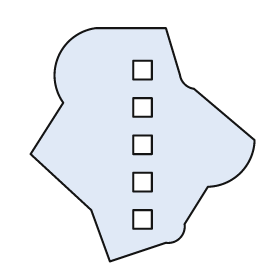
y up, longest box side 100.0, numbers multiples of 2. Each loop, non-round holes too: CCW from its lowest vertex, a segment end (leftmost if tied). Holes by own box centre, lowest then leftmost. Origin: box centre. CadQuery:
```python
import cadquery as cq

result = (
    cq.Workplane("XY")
    .moveTo(-14.0, -50.0)
    .lineTo(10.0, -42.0)
    .threePointArc((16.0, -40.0), (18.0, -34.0))
    .lineTo(28.0, -18.0)
    .threePointArc((42.0, -12.0), (48.0, 2.0))
    .lineTo(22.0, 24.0)
    .threePointArc((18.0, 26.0), (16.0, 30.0))
    .lineTo(10.0, 50.0)
    .lineTo(-20.0, 50.0)
    .threePointArc((-36.0, 38.0), (-34.0, 18.0))
    .lineTo(-48.0, -4.0)
    .lineTo(-22.0, -28.0)
    .close()
    .moveTo(-4.0, -36.0)
    .lineTo(4.0, -36.0)
    .lineTo(4.0, -28.0)
    .lineTo(-4.0, -28.0)
    .close()
    .moveTo(-4.0, -20.0)
    .lineTo(4.0, -20.0)
    .lineTo(4.0, -12.0)
    .lineTo(-4.0, -12.0)
    .close()
    .moveTo(-4.0, -4.0)
    .lineTo(4.0, -4.0)
    .lineTo(4.0, 4.0)
    .lineTo(-4.0, 4.0)
    .close()
    .moveTo(-4.0, 12.0)
    .lineTo(4.0, 12.0)
    .lineTo(4.0, 20.0)
    .lineTo(-4.0, 20.0)
    .close()
    .moveTo(-4.0, 28.0)
    .lineTo(4.0, 28.0)
    .lineTo(4.0, 36.0)
    .lineTo(-4.0, 36.0)
    .close()
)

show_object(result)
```